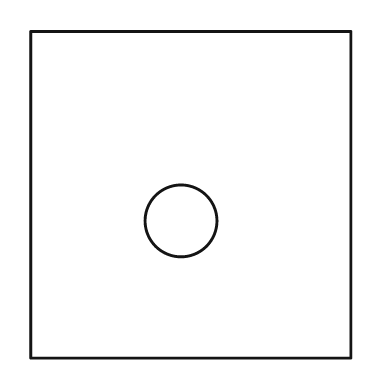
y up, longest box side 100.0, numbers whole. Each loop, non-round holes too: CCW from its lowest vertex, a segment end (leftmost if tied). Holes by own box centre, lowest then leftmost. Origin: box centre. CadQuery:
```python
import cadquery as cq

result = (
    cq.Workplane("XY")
    .moveTo(-49.0, -50.0)
    .lineTo(49.0, -50.0)
    .lineTo(49.0, 50.0)
    .lineTo(-49.0, 50.0)
    .close()
    .moveTo(-3.0, -8.0)
    .circle(11.0)
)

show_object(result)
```